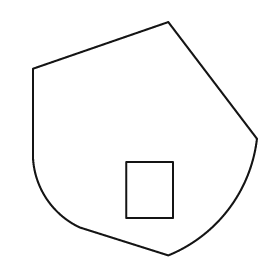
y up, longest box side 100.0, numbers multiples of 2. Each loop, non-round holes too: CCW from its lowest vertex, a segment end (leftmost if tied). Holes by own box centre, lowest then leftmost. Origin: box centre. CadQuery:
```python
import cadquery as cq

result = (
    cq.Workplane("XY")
    .moveTo(10.0, -50.0)
    .threePointArc((36.0, -30.0), (48.0, 0.0))
    .lineTo(10.0, 50.0)
    .lineTo(-48.0, 30.0)
    .lineTo(-48.0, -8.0)
    .threePointArc((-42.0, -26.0), (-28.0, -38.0))
    .close()
    .moveTo(-8.0, -34.0)
    .lineTo(12.0, -34.0)
    .lineTo(12.0, -10.0)
    .lineTo(-8.0, -10.0)
    .close()
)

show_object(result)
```